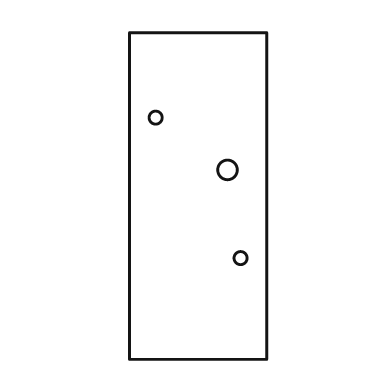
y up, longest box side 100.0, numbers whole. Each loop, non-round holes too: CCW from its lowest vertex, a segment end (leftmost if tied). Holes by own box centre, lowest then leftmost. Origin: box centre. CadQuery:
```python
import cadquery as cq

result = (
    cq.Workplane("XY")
    .moveTo(-21.0, -50.0)
    .lineTo(21.0, -50.0)
    .lineTo(21.0, 50.0)
    .lineTo(-21.0, 50.0)
    .close()
    .moveTo(13.0, -19.0)
    .circle(2.0)
    .moveTo(9.0, 8.0)
    .circle(3.0)
    .moveTo(-13.0, 24.0)
    .circle(2.0)
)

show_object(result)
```